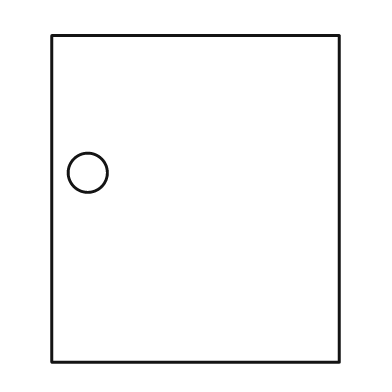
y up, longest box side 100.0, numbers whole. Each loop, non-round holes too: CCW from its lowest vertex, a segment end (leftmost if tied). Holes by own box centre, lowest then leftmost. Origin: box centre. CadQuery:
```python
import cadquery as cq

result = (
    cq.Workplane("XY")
    .moveTo(-44.0, -50.0)
    .lineTo(44.0, -50.0)
    .lineTo(44.0, 50.0)
    .lineTo(-44.0, 50.0)
    .close()
    .moveTo(-33.0, 8.0)
    .circle(6.0)
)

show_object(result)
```